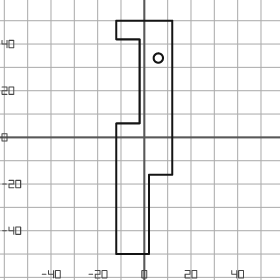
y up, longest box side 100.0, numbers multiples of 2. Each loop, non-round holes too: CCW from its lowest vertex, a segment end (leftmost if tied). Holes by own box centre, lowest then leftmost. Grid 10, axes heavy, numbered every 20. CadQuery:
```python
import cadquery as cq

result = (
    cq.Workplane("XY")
    .moveTo(-12.0, -50.0)
    .lineTo(2.0, -50.0)
    .lineTo(2.0, -16.0)
    .lineTo(12.0, -16.0)
    .lineTo(12.0, 50.0)
    .lineTo(-12.0, 50.0)
    .lineTo(-12.0, 42.0)
    .lineTo(-2.0, 42.0)
    .lineTo(-2.0, 6.0)
    .lineTo(-12.0, 6.0)
    .close()
    .moveTo(6.0, 34.0)
    .circle(2.0)
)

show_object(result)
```